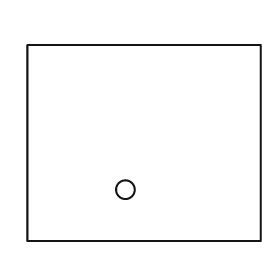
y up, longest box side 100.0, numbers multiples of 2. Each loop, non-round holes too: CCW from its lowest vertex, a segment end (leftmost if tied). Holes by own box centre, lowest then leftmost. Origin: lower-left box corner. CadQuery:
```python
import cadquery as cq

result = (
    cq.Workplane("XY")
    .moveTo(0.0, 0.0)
    .lineTo(100.0, 0.0)
    .lineTo(100.0, 84.0)
    .lineTo(0.0, 84.0)
    .close()
    .moveTo(42.0, 22.0)
    .circle(4.0)
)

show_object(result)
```